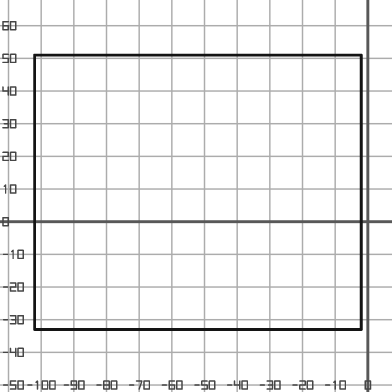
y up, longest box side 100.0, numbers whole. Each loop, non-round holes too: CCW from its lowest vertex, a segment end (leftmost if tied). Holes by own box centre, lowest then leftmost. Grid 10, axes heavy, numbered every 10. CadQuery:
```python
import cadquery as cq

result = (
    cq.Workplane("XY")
    .moveTo(-102.0, -33.0)
    .lineTo(-2.0, -33.0)
    .lineTo(-2.0, 51.0)
    .lineTo(-102.0, 51.0)
    .close()
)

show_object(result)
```